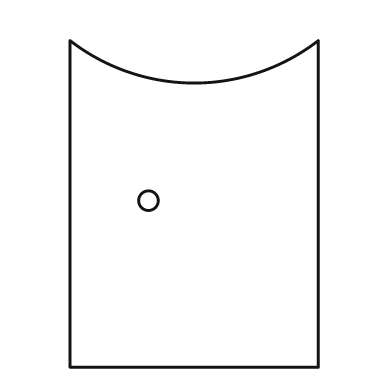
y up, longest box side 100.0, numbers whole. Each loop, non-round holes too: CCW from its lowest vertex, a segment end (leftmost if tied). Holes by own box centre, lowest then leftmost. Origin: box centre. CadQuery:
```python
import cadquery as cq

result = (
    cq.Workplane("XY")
    .moveTo(-38.0, -50.0)
    .lineTo(38.0, -50.0)
    .lineTo(38.0, 50.0)
    .threePointArc((0.0, 37.0), (-38.0, 50.0))
    .close()
    .moveTo(-14.0, 1.0)
    .circle(3.0)
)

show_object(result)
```